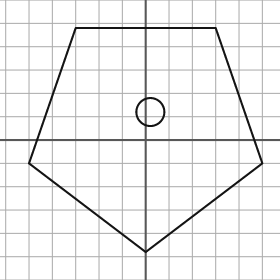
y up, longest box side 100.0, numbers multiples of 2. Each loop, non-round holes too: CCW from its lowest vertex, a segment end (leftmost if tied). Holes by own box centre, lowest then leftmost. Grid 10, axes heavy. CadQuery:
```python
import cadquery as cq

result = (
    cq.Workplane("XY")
    .moveTo(0.0, -48.0)
    .lineTo(50.0, -10.0)
    .lineTo(30.0, 48.0)
    .lineTo(-30.0, 48.0)
    .lineTo(-50.0, -10.0)
    .close()
    .moveTo(2.0, 12.0)
    .circle(6.0)
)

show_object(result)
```